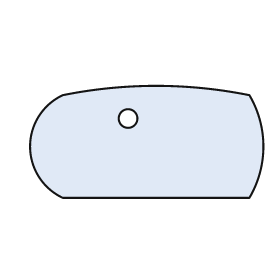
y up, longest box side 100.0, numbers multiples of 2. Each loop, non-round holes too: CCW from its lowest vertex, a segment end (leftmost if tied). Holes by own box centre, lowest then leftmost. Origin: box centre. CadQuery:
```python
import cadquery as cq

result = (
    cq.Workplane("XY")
    .moveTo(-36.0, -24.0)
    .lineTo(44.0, -24.0)
    .threePointArc((50.0, -2.0), (44.0, 20.0))
    .threePointArc((4.0, 24.0), (-36.0, 20.0))
    .threePointArc((-50.0, -2.0), (-36.0, -24.0))
    .close()
    .moveTo(-8.0, 10.0)
    .circle(4.0)
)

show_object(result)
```